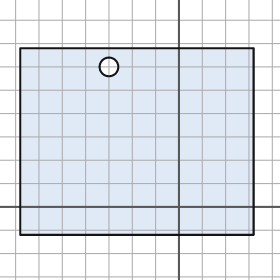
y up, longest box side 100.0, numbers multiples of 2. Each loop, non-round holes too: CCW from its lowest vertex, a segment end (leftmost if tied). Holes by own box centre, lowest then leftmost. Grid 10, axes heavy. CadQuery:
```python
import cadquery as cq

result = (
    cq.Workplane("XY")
    .moveTo(-68.0, -12.0)
    .lineTo(32.0, -12.0)
    .lineTo(32.0, 68.0)
    .lineTo(-68.0, 68.0)
    .close()
    .moveTo(-30.0, 60.0)
    .circle(4.0)
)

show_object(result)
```